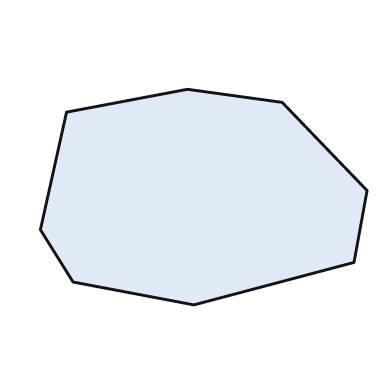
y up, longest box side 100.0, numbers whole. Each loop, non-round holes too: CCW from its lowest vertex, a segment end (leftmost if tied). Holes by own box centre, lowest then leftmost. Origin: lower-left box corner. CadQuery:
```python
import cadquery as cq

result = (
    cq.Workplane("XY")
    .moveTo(47.0, 0.0)
    .lineTo(96.0, 13.0)
    .lineTo(100.0, 35.0)
    .lineTo(74.0, 62.0)
    .lineTo(45.0, 66.0)
    .lineTo(8.0, 59.0)
    .lineTo(0.0, 23.0)
    .lineTo(10.0, 7.0)
    .close()
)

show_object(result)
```